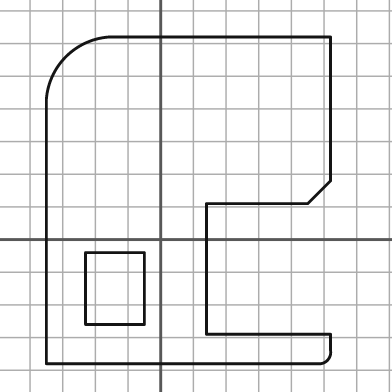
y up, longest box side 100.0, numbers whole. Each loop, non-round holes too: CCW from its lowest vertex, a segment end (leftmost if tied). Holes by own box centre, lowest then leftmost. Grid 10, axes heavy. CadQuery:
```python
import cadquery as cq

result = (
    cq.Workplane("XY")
    .moveTo(-35.0, -38.0)
    .lineTo(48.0, -38.0)
    .threePointArc((51.0, -37.0), (52.0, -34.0))
    .lineTo(52.0, -29.0)
    .lineTo(14.0, -29.0)
    .lineTo(14.0, 11.0)
    .lineTo(45.0, 11.0)
    .lineTo(52.0, 18.0)
    .lineTo(52.0, 62.0)
    .lineTo(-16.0, 62.0)
    .threePointArc((-29.0, 56.0), (-35.0, 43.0))
    .close()
    .moveTo(-23.0, -26.0)
    .lineTo(-5.0, -26.0)
    .lineTo(-5.0, -4.0)
    .lineTo(-23.0, -4.0)
    .close()
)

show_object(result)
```